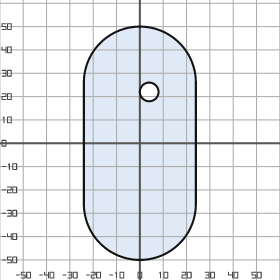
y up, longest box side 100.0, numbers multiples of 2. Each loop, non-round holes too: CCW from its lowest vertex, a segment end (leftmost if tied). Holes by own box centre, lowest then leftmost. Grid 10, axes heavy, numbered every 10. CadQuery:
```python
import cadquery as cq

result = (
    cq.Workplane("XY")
    .moveTo(-24.0, -26.0)
    .threePointArc((0.0, -50.0), (24.0, -26.0))
    .lineTo(24.0, 26.0)
    .threePointArc((0.0, 50.0), (-24.0, 26.0))
    .close()
    .moveTo(4.0, 22.0)
    .circle(4.0)
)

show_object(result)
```